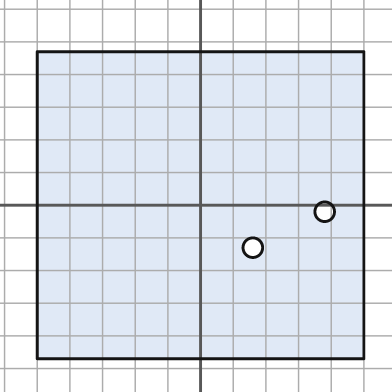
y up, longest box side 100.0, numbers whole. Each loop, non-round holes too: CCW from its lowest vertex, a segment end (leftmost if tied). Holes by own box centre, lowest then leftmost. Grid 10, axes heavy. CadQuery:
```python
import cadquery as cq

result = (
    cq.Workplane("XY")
    .moveTo(-50.0, -47.0)
    .lineTo(50.0, -47.0)
    .lineTo(50.0, 47.0)
    .lineTo(-50.0, 47.0)
    .close()
    .moveTo(16.0, -13.0)
    .circle(3.0)
    .moveTo(38.0, -2.0)
    .circle(3.0)
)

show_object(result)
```